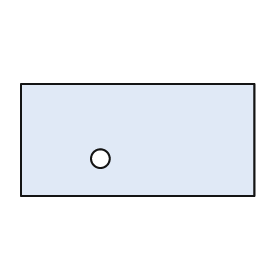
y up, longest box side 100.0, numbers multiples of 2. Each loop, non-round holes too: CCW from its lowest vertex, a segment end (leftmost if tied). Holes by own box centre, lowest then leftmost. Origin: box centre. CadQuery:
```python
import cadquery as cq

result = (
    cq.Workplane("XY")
    .moveTo(-50.0, -24.0)
    .lineTo(50.0, -24.0)
    .lineTo(50.0, 24.0)
    .lineTo(-50.0, 24.0)
    .close()
    .moveTo(-16.0, -8.0)
    .circle(4.0)
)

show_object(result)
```